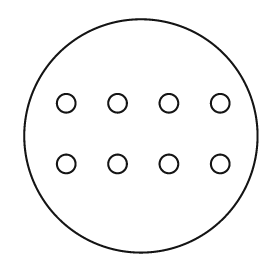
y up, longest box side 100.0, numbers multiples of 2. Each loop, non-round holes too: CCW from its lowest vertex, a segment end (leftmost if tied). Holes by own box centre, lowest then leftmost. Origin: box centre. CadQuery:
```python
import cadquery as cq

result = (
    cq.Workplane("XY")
    .moveTo(0.0, 0.0)
    .circle(50.0)
    .moveTo(-32.0, -12.0)
    .circle(4.0)
    .moveTo(-10.0, -12.0)
    .circle(4.0)
    .moveTo(12.0, -12.0)
    .circle(4.0)
    .moveTo(34.0, -12.0)
    .circle(4.0)
    .moveTo(-32.0, 14.0)
    .circle(4.0)
    .moveTo(-10.0, 14.0)
    .circle(4.0)
    .moveTo(12.0, 14.0)
    .circle(4.0)
    .moveTo(34.0, 14.0)
    .circle(4.0)
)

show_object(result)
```